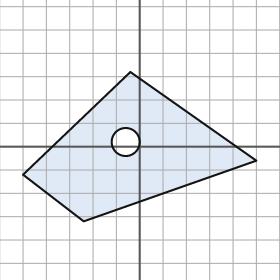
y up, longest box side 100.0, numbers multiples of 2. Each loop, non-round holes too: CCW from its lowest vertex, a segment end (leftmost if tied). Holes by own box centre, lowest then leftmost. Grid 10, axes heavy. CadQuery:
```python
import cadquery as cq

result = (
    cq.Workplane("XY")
    .moveTo(-24.0, -32.0)
    .lineTo(50.0, -6.0)
    .lineTo(-4.0, 32.0)
    .lineTo(-50.0, -12.0)
    .close()
    .moveTo(-6.0, 2.0)
    .circle(6.0)
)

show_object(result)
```